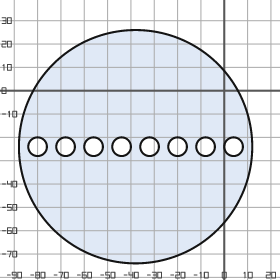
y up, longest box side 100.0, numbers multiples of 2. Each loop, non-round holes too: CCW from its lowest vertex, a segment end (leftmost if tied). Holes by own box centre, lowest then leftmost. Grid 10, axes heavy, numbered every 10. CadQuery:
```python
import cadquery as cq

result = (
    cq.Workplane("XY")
    .moveTo(-38.0, -24.0)
    .circle(50.0)
    .moveTo(-80.0, -24.0)
    .circle(4.0)
    .moveTo(-68.0, -24.0)
    .circle(4.0)
    .moveTo(-56.0, -24.0)
    .circle(4.0)
    .moveTo(-44.0, -24.0)
    .circle(4.0)
    .moveTo(-32.0, -24.0)
    .circle(4.0)
    .moveTo(-20.0, -24.0)
    .circle(4.0)
    .moveTo(-8.0, -24.0)
    .circle(4.0)
    .moveTo(4.0, -24.0)
    .circle(4.0)
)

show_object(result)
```